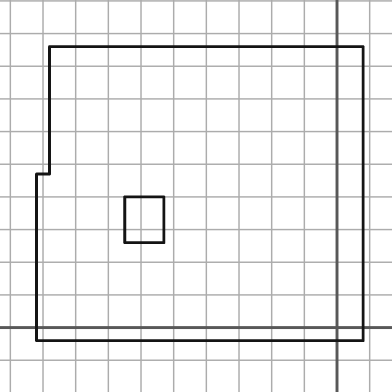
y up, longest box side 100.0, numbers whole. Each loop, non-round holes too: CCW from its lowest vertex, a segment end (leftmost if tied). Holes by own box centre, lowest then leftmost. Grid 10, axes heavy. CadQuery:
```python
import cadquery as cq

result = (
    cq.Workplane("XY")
    .moveTo(-92.0, -4.0)
    .lineTo(8.0, -4.0)
    .lineTo(8.0, 86.0)
    .lineTo(-88.0, 86.0)
    .lineTo(-88.0, 47.0)
    .lineTo(-92.0, 47.0)
    .close()
    .moveTo(-65.0, 26.0)
    .lineTo(-53.0, 26.0)
    .lineTo(-53.0, 40.0)
    .lineTo(-65.0, 40.0)
    .close()
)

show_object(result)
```